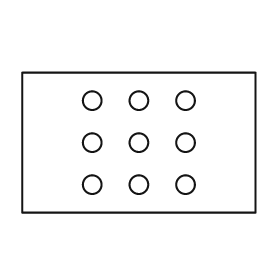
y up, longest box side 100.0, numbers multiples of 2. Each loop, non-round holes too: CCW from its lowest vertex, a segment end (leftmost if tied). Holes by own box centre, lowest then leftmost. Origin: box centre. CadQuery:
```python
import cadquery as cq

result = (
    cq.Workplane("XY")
    .moveTo(-50.0, -30.0)
    .lineTo(50.0, -30.0)
    .lineTo(50.0, 30.0)
    .lineTo(-50.0, 30.0)
    .close()
    .moveTo(-20.0, -18.0)
    .circle(4.0)
    .moveTo(0.0, -18.0)
    .circle(4.0)
    .moveTo(20.0, -18.0)
    .circle(4.0)
    .moveTo(-20.0, 0.0)
    .circle(4.0)
    .moveTo(0.0, 0.0)
    .circle(4.0)
    .moveTo(20.0, 0.0)
    .circle(4.0)
    .moveTo(-20.0, 18.0)
    .circle(4.0)
    .moveTo(0.0, 18.0)
    .circle(4.0)
    .moveTo(20.0, 18.0)
    .circle(4.0)
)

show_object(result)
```